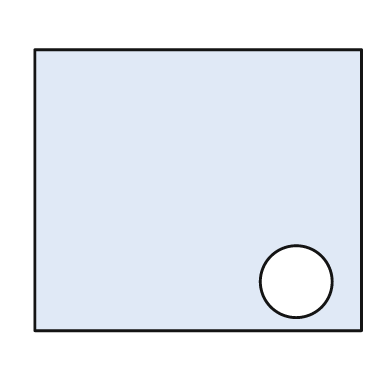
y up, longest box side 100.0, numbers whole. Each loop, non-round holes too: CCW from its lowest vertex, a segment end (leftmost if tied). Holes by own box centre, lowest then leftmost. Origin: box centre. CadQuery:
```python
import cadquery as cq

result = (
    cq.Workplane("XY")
    .moveTo(-50.0, -43.0)
    .lineTo(50.0, -43.0)
    .lineTo(50.0, 43.0)
    .lineTo(-50.0, 43.0)
    .close()
    .moveTo(30.0, -28.0)
    .circle(11.0)
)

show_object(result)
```